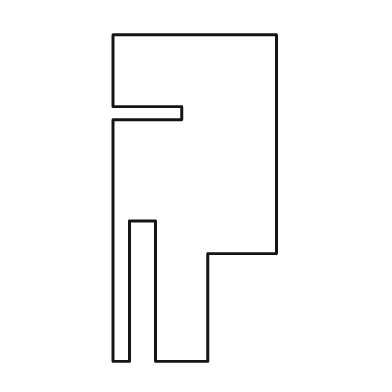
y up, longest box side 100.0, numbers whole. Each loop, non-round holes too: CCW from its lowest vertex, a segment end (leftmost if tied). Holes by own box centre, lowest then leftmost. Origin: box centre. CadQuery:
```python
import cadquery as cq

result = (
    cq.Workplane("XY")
    .moveTo(-25.0, -50.0)
    .lineTo(-20.0, -50.0)
    .lineTo(-20.0, -7.0)
    .lineTo(-12.0, -7.0)
    .lineTo(-12.0, -50.0)
    .lineTo(4.0, -50.0)
    .lineTo(4.0, -17.0)
    .lineTo(25.0, -17.0)
    .lineTo(25.0, 50.0)
    .lineTo(-25.0, 50.0)
    .lineTo(-25.0, 28.0)
    .lineTo(-4.0, 28.0)
    .lineTo(-4.0, 24.0)
    .lineTo(-25.0, 24.0)
    .close()
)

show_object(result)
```